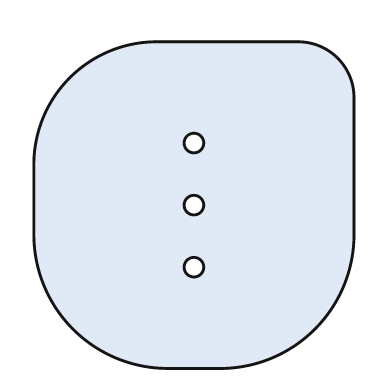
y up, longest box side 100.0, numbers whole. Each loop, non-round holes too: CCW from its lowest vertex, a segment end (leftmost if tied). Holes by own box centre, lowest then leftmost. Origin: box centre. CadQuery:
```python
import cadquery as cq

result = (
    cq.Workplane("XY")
    .moveTo(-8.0, -50.0)
    .lineTo(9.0, -50.0)
    .threePointArc((37.0, -38.0), (49.0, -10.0))
    .lineTo(49.0, 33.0)
    .threePointArc((44.0, 45.0), (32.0, 50.0))
    .lineTo(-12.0, 50.0)
    .threePointArc((-38.0, 39.0), (-49.0, 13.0))
    .lineTo(-49.0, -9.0)
    .threePointArc((-37.0, -38.0), (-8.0, -50.0))
    .close()
    .moveTo(0.0, -19.0)
    .circle(3.0)
    .moveTo(0.0, 0.0)
    .circle(3.0)
    .moveTo(0.0, 19.0)
    .circle(3.0)
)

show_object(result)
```